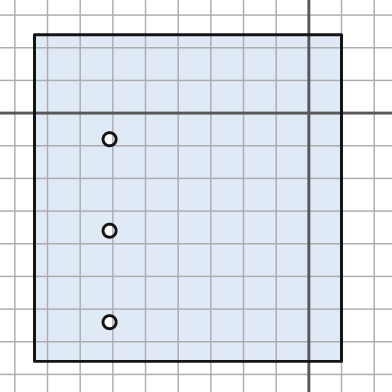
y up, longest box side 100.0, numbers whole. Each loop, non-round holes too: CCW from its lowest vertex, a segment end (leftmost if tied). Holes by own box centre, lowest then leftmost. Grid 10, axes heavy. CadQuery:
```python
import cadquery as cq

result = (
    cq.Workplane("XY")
    .moveTo(-84.0, -76.0)
    .lineTo(10.0, -76.0)
    .lineTo(10.0, 24.0)
    .lineTo(-84.0, 24.0)
    .close()
    .moveTo(-61.0, -64.0)
    .circle(2.0)
    .moveTo(-61.0, -36.0)
    .circle(2.0)
    .moveTo(-61.0, -8.0)
    .circle(2.0)
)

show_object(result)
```